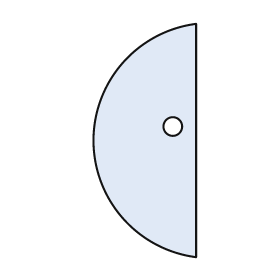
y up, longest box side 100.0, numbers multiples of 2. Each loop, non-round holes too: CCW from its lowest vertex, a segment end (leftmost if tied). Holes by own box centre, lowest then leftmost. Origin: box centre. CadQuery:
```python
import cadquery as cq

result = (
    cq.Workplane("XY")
    .moveTo(22.0, -50.0)
    .lineTo(22.0, 50.0)
    .threePointArc((-22.0, 0.0), (22.0, -50.0))
    .close()
    .moveTo(12.0, 6.0)
    .circle(4.0)
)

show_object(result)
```